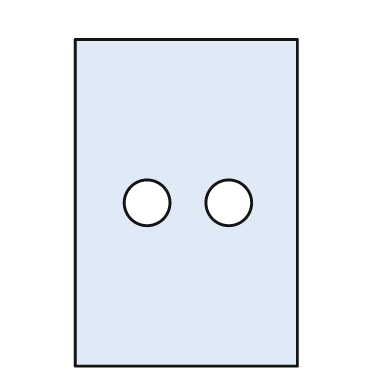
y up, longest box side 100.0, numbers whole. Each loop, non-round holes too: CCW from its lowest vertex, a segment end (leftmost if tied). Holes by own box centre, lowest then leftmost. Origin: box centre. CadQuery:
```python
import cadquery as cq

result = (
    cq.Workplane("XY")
    .moveTo(-34.0, -50.0)
    .lineTo(34.0, -50.0)
    .lineTo(34.0, 50.0)
    .lineTo(-34.0, 50.0)
    .close()
    .moveTo(-12.0, 0.0)
    .circle(7.0)
    .moveTo(13.0, 0.0)
    .circle(7.0)
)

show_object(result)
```